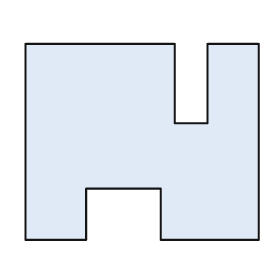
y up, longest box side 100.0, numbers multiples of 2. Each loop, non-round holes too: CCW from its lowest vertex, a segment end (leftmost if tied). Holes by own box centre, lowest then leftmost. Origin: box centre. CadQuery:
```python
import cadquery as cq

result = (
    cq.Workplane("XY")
    .moveTo(-50.0, -42.0)
    .lineTo(-24.0, -42.0)
    .lineTo(-24.0, -20.0)
    .lineTo(8.0, -20.0)
    .lineTo(8.0, -42.0)
    .lineTo(50.0, -42.0)
    .lineTo(50.0, 42.0)
    .lineTo(28.0, 42.0)
    .lineTo(28.0, 8.0)
    .lineTo(14.0, 8.0)
    .lineTo(14.0, 42.0)
    .lineTo(-50.0, 42.0)
    .close()
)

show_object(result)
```